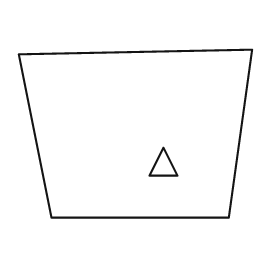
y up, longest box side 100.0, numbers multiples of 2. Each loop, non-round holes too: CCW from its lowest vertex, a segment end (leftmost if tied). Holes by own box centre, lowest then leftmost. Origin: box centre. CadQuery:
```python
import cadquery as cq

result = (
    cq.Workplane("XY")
    .moveTo(-36.0, -36.0)
    .lineTo(40.0, -36.0)
    .lineTo(50.0, 36.0)
    .lineTo(-50.0, 34.0)
    .close()
    .moveTo(6.0, -18.0)
    .lineTo(18.0, -18.0)
    .lineTo(12.0, -6.0)
    .close()
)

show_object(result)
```